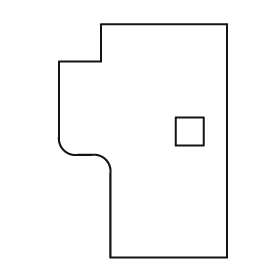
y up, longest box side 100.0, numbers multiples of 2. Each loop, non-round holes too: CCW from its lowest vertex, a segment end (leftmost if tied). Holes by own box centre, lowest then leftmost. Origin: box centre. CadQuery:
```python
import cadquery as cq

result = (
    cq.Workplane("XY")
    .moveTo(-14.0, -50.0)
    .lineTo(36.0, -50.0)
    .lineTo(36.0, 50.0)
    .lineTo(-18.0, 50.0)
    .lineTo(-18.0, 34.0)
    .lineTo(-36.0, 34.0)
    .lineTo(-36.0, 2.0)
    .threePointArc((-34.0, -4.0), (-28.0, -6.0))
    .lineTo(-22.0, -6.0)
    .threePointArc((-16.0, -8.0), (-14.0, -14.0))
    .close()
    .moveTo(14.0, -2.0)
    .lineTo(26.0, -2.0)
    .lineTo(26.0, 10.0)
    .lineTo(14.0, 10.0)
    .close()
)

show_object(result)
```